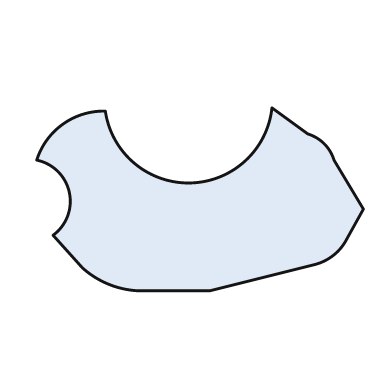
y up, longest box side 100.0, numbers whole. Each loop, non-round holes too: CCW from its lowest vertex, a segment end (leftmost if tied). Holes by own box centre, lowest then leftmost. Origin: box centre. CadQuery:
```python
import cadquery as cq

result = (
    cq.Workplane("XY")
    .moveTo(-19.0, -28.0)
    .lineTo(3.0, -28.0)
    .lineTo(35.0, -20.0)
    .threePointArc((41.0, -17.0), (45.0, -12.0))
    .lineTo(50.0, -3.0)
    .lineTo(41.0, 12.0)
    .threePointArc((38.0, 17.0), (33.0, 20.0))
    .lineTo(22.0, 28.0)
    .threePointArc((-3.0, 5.0), (-29.0, 27.0))
    .threePointArc((-42.0, 23.0), (-50.0, 12.0))
    .threePointArc((-40.0, 2.0), (-45.0, -11.0))
    .lineTo(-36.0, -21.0)
    .threePointArc((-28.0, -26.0), (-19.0, -28.0))
    .close()
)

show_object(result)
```